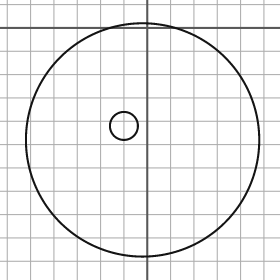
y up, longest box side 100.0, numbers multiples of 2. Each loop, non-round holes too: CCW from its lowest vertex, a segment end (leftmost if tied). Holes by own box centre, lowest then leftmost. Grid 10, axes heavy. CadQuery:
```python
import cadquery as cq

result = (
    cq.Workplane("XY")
    .moveTo(-2.0, -48.0)
    .circle(50.0)
    .moveTo(-10.0, -42.0)
    .circle(6.0)
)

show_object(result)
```